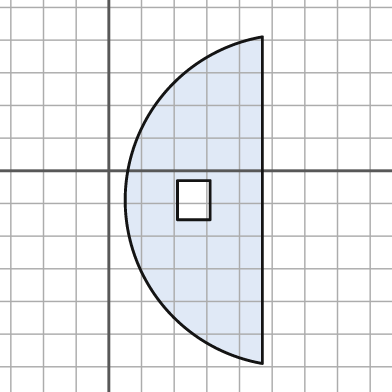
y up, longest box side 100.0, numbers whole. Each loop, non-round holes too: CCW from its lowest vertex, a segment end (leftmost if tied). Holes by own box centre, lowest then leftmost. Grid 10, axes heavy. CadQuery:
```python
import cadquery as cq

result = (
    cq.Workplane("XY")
    .moveTo(47.0, -59.0)
    .lineTo(47.0, 41.0)
    .threePointArc((5.0, -9.0), (47.0, -59.0))
    .close()
    .moveTo(21.0, -15.0)
    .lineTo(31.0, -15.0)
    .lineTo(31.0, -3.0)
    .lineTo(21.0, -3.0)
    .close()
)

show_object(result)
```